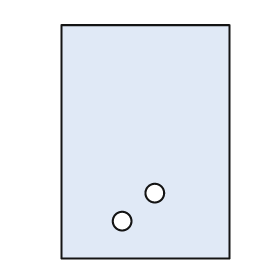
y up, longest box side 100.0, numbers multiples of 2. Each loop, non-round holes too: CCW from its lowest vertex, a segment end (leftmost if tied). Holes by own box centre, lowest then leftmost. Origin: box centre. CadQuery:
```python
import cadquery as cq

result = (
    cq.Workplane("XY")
    .moveTo(-36.0, -50.0)
    .lineTo(36.0, -50.0)
    .lineTo(36.0, 50.0)
    .lineTo(-36.0, 50.0)
    .close()
    .moveTo(-10.0, -34.0)
    .circle(4.0)
    .moveTo(4.0, -22.0)
    .circle(4.0)
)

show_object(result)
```